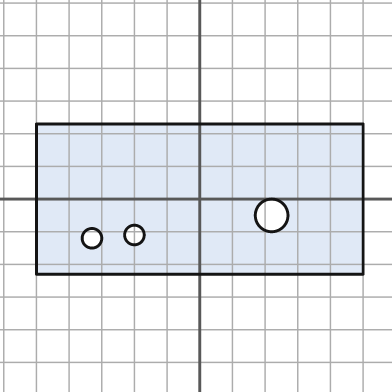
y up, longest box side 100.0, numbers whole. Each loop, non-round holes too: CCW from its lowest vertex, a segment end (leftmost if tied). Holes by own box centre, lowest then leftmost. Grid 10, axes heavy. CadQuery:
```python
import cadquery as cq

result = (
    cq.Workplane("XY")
    .moveTo(-50.0, -23.0)
    .lineTo(50.0, -23.0)
    .lineTo(50.0, 23.0)
    .lineTo(-50.0, 23.0)
    .close()
    .moveTo(-33.0, -12.0)
    .circle(3.0)
    .moveTo(-20.0, -11.0)
    .circle(3.0)
    .moveTo(22.0, -5.0)
    .circle(5.0)
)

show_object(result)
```